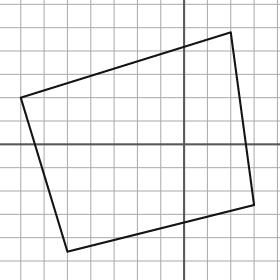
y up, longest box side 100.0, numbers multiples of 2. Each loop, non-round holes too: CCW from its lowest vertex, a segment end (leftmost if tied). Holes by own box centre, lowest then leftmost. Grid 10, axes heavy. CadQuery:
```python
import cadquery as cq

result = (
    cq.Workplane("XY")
    .moveTo(-50.0, -46.0)
    .lineTo(30.0, -26.0)
    .lineTo(20.0, 48.0)
    .lineTo(-70.0, 20.0)
    .close()
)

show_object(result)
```